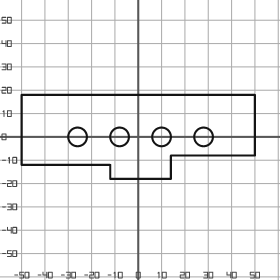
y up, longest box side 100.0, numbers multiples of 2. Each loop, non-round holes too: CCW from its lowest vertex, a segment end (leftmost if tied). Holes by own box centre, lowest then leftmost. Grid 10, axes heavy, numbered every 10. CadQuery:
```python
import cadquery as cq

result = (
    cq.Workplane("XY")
    .moveTo(-12.0, -18.0)
    .lineTo(14.0, -18.0)
    .lineTo(14.0, -8.0)
    .lineTo(50.0, -8.0)
    .lineTo(50.0, 18.0)
    .lineTo(-50.0, 18.0)
    .lineTo(-50.0, -12.0)
    .lineTo(-12.0, -12.0)
    .close()
    .moveTo(-26.0, 0.0)
    .circle(4.0)
    .moveTo(-8.0, 0.0)
    .circle(4.0)
    .moveTo(10.0, 0.0)
    .circle(4.0)
    .moveTo(28.0, 0.0)
    .circle(4.0)
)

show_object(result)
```